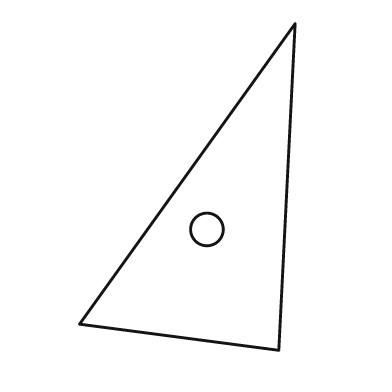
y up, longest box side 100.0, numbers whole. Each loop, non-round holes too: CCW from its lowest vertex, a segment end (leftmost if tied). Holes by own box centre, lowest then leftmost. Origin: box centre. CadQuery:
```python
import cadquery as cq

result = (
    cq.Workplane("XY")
    .moveTo(28.0, -50.0)
    .lineTo(33.0, 50.0)
    .lineTo(-33.0, -42.0)
    .close()
    .moveTo(6.0, -13.0)
    .circle(5.0)
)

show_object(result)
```